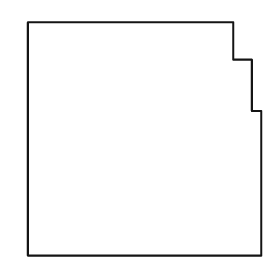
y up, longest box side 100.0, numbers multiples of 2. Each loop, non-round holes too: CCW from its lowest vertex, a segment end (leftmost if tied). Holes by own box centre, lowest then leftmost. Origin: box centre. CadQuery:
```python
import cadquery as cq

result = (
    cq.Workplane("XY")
    .moveTo(-50.0, -50.0)
    .lineTo(50.0, -50.0)
    .lineTo(50.0, 12.0)
    .lineTo(46.0, 12.0)
    .lineTo(46.0, 34.0)
    .lineTo(38.0, 34.0)
    .lineTo(38.0, 50.0)
    .lineTo(-50.0, 50.0)
    .close()
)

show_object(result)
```